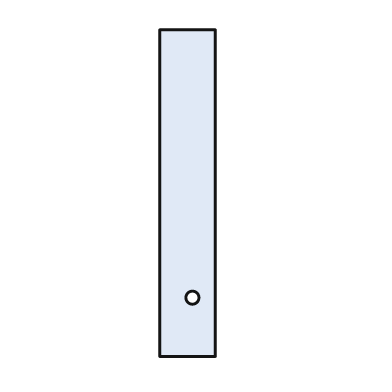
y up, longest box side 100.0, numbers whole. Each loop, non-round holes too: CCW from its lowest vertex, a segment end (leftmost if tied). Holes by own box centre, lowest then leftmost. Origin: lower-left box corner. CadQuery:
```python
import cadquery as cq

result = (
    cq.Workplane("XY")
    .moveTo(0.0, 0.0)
    .lineTo(17.0, 0.0)
    .lineTo(17.0, 100.0)
    .lineTo(0.0, 100.0)
    .close()
    .moveTo(10.0, 18.0)
    .circle(2.0)
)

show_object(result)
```